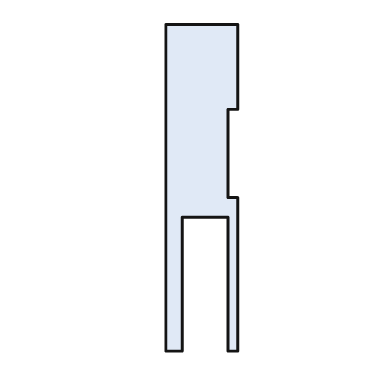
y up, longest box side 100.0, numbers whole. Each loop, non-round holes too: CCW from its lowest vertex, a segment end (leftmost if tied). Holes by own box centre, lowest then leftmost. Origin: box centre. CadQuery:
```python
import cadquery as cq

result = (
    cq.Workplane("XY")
    .moveTo(-11.0, -50.0)
    .lineTo(-6.0, -50.0)
    .lineTo(-6.0, -9.0)
    .lineTo(8.0, -9.0)
    .lineTo(8.0, -50.0)
    .lineTo(11.0, -50.0)
    .lineTo(11.0, -3.0)
    .lineTo(8.0, -3.0)
    .lineTo(8.0, 24.0)
    .lineTo(11.0, 24.0)
    .lineTo(11.0, 50.0)
    .lineTo(-11.0, 50.0)
    .close()
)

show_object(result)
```